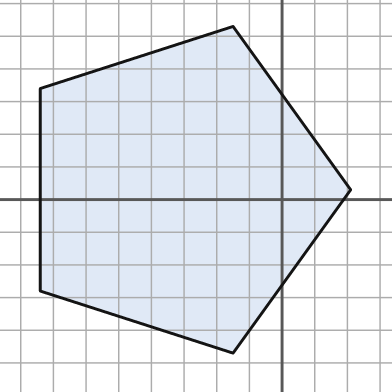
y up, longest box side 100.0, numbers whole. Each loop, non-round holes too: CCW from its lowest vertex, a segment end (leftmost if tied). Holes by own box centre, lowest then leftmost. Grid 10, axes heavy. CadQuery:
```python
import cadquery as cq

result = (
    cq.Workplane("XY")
    .moveTo(-15.0, -47.0)
    .lineTo(21.0, 3.0)
    .lineTo(-15.0, 53.0)
    .lineTo(-74.0, 34.0)
    .lineTo(-74.0, -28.0)
    .close()
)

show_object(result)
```